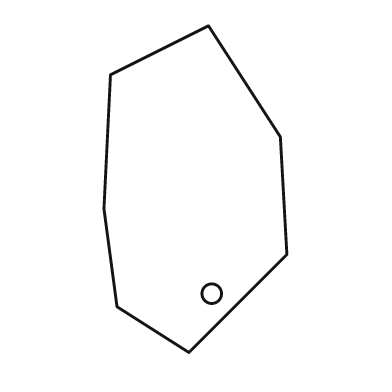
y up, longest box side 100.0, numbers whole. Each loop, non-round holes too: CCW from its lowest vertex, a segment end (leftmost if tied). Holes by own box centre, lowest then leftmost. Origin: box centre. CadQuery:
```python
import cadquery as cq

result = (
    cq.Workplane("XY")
    .moveTo(-2.0, -50.0)
    .lineTo(28.0, -20.0)
    .lineTo(26.0, 16.0)
    .lineTo(4.0, 50.0)
    .lineTo(-26.0, 35.0)
    .lineTo(-28.0, -6.0)
    .lineTo(-24.0, -36.0)
    .close()
    .moveTo(5.0, -32.0)
    .circle(3.0)
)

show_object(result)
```